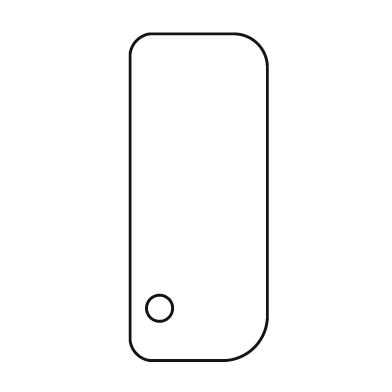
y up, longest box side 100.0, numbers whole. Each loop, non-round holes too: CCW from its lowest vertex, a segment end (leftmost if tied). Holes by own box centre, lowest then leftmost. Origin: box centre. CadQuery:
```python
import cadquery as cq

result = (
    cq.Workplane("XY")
    .moveTo(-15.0, -50.0)
    .lineTo(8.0, -50.0)
    .threePointArc((17.0, -46.0), (21.0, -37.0))
    .lineTo(21.0, 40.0)
    .threePointArc((18.0, 47.0), (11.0, 50.0))
    .lineTo(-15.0, 50.0)
    .threePointArc((-19.0, 48.0), (-21.0, 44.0))
    .lineTo(-21.0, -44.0)
    .threePointArc((-19.0, -48.0), (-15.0, -50.0))
    .close()
    .moveTo(-12.0, -34.0)
    .circle(4.0)
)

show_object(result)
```